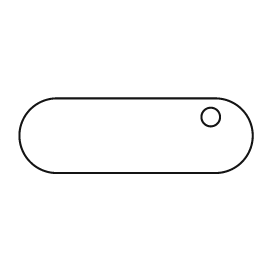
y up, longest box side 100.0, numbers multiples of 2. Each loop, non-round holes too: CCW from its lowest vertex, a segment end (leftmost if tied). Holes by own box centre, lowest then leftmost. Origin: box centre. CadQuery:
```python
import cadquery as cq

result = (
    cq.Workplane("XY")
    .moveTo(-34.0, -16.0)
    .lineTo(34.0, -16.0)
    .threePointArc((50.0, 0.0), (34.0, 16.0))
    .lineTo(-34.0, 16.0)
    .threePointArc((-50.0, 0.0), (-34.0, -16.0))
    .close()
    .moveTo(32.0, 8.0)
    .circle(4.0)
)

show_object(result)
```